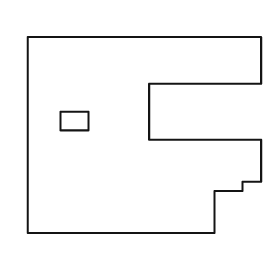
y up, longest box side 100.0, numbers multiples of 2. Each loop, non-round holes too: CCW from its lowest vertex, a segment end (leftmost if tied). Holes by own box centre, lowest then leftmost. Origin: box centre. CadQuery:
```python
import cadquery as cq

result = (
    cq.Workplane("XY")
    .moveTo(-50.0, -42.0)
    .lineTo(30.0, -42.0)
    .lineTo(30.0, -24.0)
    .lineTo(42.0, -24.0)
    .lineTo(42.0, -20.0)
    .lineTo(50.0, -20.0)
    .lineTo(50.0, -2.0)
    .lineTo(2.0, -2.0)
    .lineTo(2.0, 22.0)
    .lineTo(50.0, 22.0)
    .lineTo(50.0, 42.0)
    .lineTo(-50.0, 42.0)
    .close()
    .moveTo(-36.0, 2.0)
    .lineTo(-24.0, 2.0)
    .lineTo(-24.0, 10.0)
    .lineTo(-36.0, 10.0)
    .close()
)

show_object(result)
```